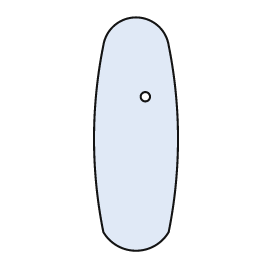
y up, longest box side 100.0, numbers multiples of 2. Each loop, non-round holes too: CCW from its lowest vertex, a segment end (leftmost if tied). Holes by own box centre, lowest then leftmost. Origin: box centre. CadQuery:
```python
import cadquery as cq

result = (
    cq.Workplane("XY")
    .moveTo(-14.0, -42.0)
    .threePointArc((0.0, -50.0), (14.0, -42.0))
    .threePointArc((18.0, -2.0), (14.0, 38.0))
    .threePointArc((0.0, 50.0), (-14.0, 38.0))
    .threePointArc((-18.0, -2.0), (-14.0, -42.0))
    .close()
    .moveTo(4.0, 16.0)
    .circle(2.0)
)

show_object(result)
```